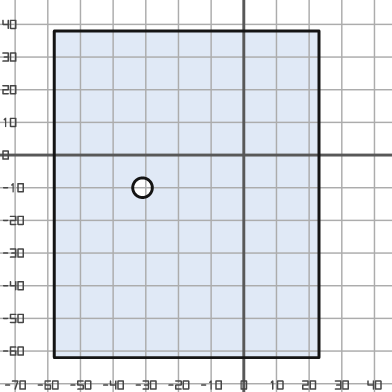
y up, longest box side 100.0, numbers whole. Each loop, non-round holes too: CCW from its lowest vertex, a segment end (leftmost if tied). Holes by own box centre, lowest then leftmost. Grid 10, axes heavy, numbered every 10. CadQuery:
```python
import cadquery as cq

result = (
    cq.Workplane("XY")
    .moveTo(-58.0, -62.0)
    .lineTo(23.0, -62.0)
    .lineTo(23.0, 38.0)
    .lineTo(-58.0, 38.0)
    .close()
    .moveTo(-31.0, -10.0)
    .circle(3.0)
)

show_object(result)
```